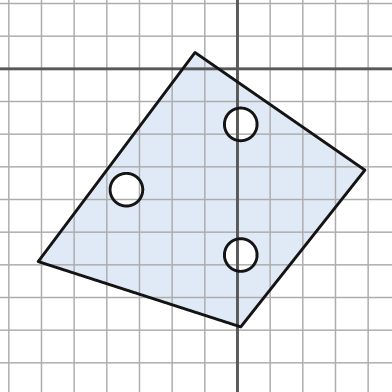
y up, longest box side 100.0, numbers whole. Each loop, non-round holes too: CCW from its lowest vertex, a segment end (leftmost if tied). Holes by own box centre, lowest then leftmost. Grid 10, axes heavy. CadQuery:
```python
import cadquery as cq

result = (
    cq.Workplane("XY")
    .moveTo(1.0, -79.0)
    .lineTo(39.0, -31.0)
    .lineTo(-13.0, 5.0)
    .lineTo(-61.0, -59.0)
    .close()
    .moveTo(1.0, -57.0)
    .circle(5.0)
    .moveTo(-34.0, -37.0)
    .circle(5.0)
    .moveTo(1.0, -17.0)
    .circle(5.0)
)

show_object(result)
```